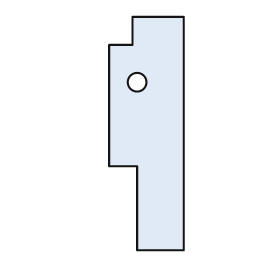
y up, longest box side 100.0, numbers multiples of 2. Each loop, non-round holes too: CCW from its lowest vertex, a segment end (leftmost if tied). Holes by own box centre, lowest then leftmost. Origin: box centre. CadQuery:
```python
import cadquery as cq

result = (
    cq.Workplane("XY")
    .moveTo(-4.0, -50.0)
    .lineTo(16.0, -50.0)
    .lineTo(16.0, 50.0)
    .lineTo(-6.0, 50.0)
    .lineTo(-6.0, 38.0)
    .lineTo(-16.0, 38.0)
    .lineTo(-16.0, -14.0)
    .lineTo(-4.0, -14.0)
    .close()
    .moveTo(-4.0, 22.0)
    .circle(4.0)
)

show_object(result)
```